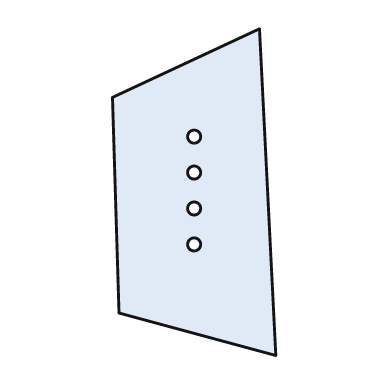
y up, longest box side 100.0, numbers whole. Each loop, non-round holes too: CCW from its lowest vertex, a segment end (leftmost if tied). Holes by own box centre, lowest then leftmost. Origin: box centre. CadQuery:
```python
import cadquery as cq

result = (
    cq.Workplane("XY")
    .moveTo(25.0, -50.0)
    .lineTo(20.0, 50.0)
    .lineTo(-25.0, 29.0)
    .lineTo(-23.0, -37.0)
    .close()
    .moveTo(0.0, -16.0)
    .circle(2.0)
    .moveTo(0.0, -5.0)
    .circle(2.0)
    .moveTo(0.0, 6.0)
    .circle(2.0)
    .moveTo(0.0, 17.0)
    .circle(2.0)
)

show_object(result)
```